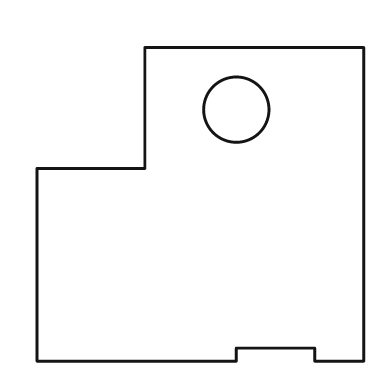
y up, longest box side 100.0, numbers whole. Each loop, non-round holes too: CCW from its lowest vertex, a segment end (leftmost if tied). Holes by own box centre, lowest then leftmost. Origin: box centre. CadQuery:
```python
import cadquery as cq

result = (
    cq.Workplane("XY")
    .moveTo(-50.0, -48.0)
    .lineTo(11.0, -48.0)
    .lineTo(11.0, -44.0)
    .lineTo(35.0, -44.0)
    .lineTo(35.0, -48.0)
    .lineTo(50.0, -48.0)
    .lineTo(50.0, 48.0)
    .lineTo(-17.0, 48.0)
    .lineTo(-17.0, 11.0)
    .lineTo(-50.0, 11.0)
    .close()
    .moveTo(11.0, 29.0)
    .circle(10.0)
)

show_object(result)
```